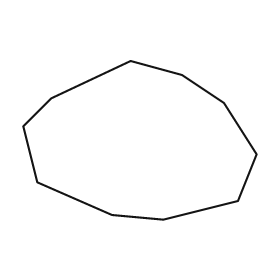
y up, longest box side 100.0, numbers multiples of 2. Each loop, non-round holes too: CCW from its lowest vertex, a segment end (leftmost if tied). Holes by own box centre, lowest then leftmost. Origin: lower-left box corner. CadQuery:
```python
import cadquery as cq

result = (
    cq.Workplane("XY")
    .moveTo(60.0, 0.0)
    .lineTo(92.0, 8.0)
    .lineTo(100.0, 28.0)
    .lineTo(86.0, 50.0)
    .lineTo(68.0, 62.0)
    .lineTo(46.0, 68.0)
    .lineTo(12.0, 52.0)
    .lineTo(0.0, 40.0)
    .lineTo(6.0, 16.0)
    .lineTo(38.0, 2.0)
    .close()
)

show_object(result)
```